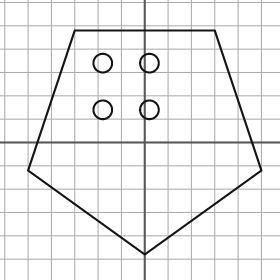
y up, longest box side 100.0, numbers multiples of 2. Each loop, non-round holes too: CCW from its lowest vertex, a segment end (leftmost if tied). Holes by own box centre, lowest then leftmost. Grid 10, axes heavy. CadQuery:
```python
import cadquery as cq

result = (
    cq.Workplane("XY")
    .moveTo(0.0, -48.0)
    .lineTo(50.0, -12.0)
    .lineTo(30.0, 48.0)
    .lineTo(-30.0, 48.0)
    .lineTo(-50.0, -12.0)
    .close()
    .moveTo(-18.0, 14.0)
    .circle(4.0)
    .moveTo(2.0, 14.0)
    .circle(4.0)
    .moveTo(-18.0, 34.0)
    .circle(4.0)
    .moveTo(2.0, 34.0)
    .circle(4.0)
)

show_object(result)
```